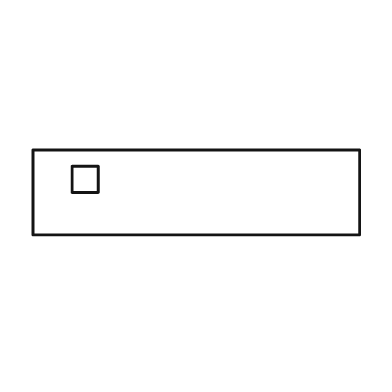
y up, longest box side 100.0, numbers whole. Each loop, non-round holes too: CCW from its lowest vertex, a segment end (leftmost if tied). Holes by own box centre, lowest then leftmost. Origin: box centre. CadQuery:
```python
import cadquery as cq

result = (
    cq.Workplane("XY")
    .moveTo(-50.0, -13.0)
    .lineTo(50.0, -13.0)
    .lineTo(50.0, 13.0)
    .lineTo(-50.0, 13.0)
    .close()
    .moveTo(-38.0, 0.0)
    .lineTo(-30.0, 0.0)
    .lineTo(-30.0, 8.0)
    .lineTo(-38.0, 8.0)
    .close()
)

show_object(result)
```